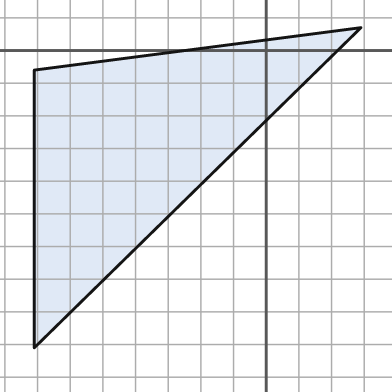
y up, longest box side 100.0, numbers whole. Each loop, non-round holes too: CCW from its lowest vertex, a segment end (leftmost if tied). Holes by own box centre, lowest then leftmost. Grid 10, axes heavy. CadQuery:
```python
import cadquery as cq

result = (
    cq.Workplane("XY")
    .moveTo(-71.0, -91.0)
    .lineTo(29.0, 7.0)
    .lineTo(-71.0, -6.0)
    .close()
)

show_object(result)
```